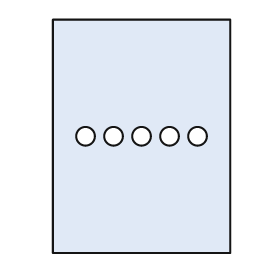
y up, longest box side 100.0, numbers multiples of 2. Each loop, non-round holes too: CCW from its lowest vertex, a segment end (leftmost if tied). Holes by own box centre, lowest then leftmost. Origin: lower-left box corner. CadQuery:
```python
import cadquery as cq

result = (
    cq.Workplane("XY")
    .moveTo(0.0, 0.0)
    .lineTo(76.0, 0.0)
    .lineTo(76.0, 100.0)
    .lineTo(0.0, 100.0)
    .close()
    .moveTo(14.0, 50.0)
    .circle(4.0)
    .moveTo(26.0, 50.0)
    .circle(4.0)
    .moveTo(38.0, 50.0)
    .circle(4.0)
    .moveTo(50.0, 50.0)
    .circle(4.0)
    .moveTo(62.0, 50.0)
    .circle(4.0)
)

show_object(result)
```